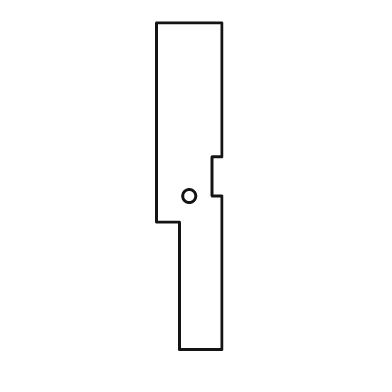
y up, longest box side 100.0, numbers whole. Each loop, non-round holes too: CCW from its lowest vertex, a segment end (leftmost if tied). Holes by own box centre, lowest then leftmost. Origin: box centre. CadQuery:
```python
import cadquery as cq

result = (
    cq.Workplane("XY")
    .moveTo(-3.0, -50.0)
    .lineTo(10.0, -50.0)
    .lineTo(10.0, -3.0)
    .lineTo(7.0, -3.0)
    .lineTo(7.0, 9.0)
    .lineTo(10.0, 9.0)
    .lineTo(10.0, 50.0)
    .lineTo(-10.0, 50.0)
    .lineTo(-10.0, -11.0)
    .lineTo(-3.0, -11.0)
    .close()
    .moveTo(0.0, -3.0)
    .circle(2.0)
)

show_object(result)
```